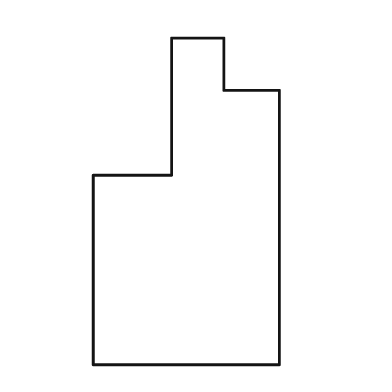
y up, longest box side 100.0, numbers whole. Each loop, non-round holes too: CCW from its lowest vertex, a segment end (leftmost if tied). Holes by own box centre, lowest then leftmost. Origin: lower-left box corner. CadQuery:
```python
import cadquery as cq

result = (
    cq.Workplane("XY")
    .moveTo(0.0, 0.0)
    .lineTo(57.0, 0.0)
    .lineTo(57.0, 84.0)
    .lineTo(40.0, 84.0)
    .lineTo(40.0, 100.0)
    .lineTo(24.0, 100.0)
    .lineTo(24.0, 58.0)
    .lineTo(0.0, 58.0)
    .close()
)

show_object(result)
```